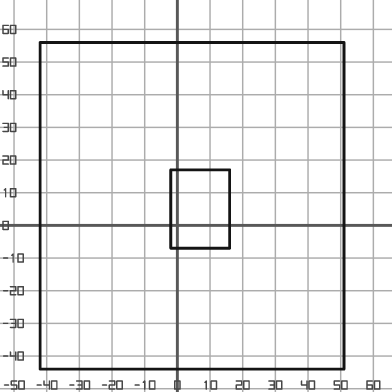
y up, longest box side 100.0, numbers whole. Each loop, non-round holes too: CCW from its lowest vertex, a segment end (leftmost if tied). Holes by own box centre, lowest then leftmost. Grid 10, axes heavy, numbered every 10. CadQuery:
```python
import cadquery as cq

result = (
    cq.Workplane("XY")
    .moveTo(-42.0, -44.0)
    .lineTo(51.0, -44.0)
    .lineTo(51.0, 56.0)
    .lineTo(-42.0, 56.0)
    .close()
    .moveTo(-2.0, -7.0)
    .lineTo(16.0, -7.0)
    .lineTo(16.0, 17.0)
    .lineTo(-2.0, 17.0)
    .close()
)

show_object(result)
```